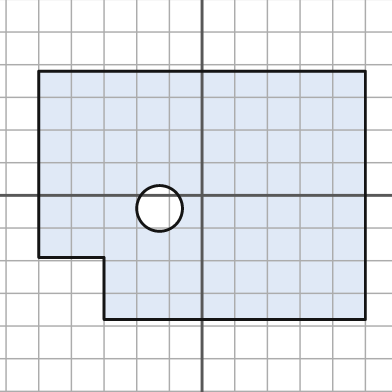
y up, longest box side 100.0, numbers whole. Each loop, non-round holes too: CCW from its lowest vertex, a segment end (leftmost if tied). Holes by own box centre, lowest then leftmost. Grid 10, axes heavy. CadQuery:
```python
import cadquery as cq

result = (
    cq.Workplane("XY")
    .moveTo(-30.0, -38.0)
    .lineTo(50.0, -38.0)
    .lineTo(50.0, 38.0)
    .lineTo(-50.0, 38.0)
    .lineTo(-50.0, -19.0)
    .lineTo(-30.0, -19.0)
    .close()
    .moveTo(-13.0, -4.0)
    .circle(7.0)
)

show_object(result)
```